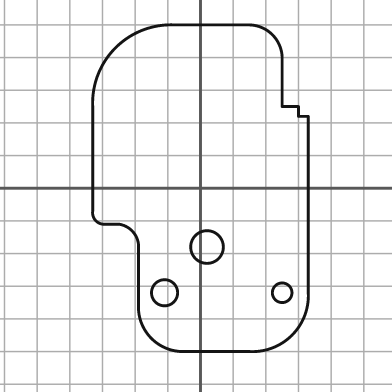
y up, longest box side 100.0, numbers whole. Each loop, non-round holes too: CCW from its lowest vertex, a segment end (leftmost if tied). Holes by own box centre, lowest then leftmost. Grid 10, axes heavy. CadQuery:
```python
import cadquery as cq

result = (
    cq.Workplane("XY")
    .moveTo(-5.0, -50.0)
    .lineTo(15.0, -50.0)
    .threePointArc((28.0, -45.0), (33.0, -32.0))
    .lineTo(33.0, 22.0)
    .lineTo(30.0, 22.0)
    .lineTo(30.0, 25.0)
    .lineTo(25.0, 25.0)
    .lineTo(25.0, 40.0)
    .threePointArc((22.0, 47.0), (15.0, 50.0))
    .lineTo(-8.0, 50.0)
    .threePointArc((-26.0, 43.0), (-33.0, 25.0))
    .lineTo(-33.0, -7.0)
    .threePointArc((-32.0, -10.0), (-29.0, -11.0))
    .lineTo(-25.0, -11.0)
    .threePointArc((-21.0, -13.0), (-19.0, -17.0))
    .lineTo(-19.0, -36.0)
    .threePointArc((-15.0, -46.0), (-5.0, -50.0))
    .close()
    .moveTo(-11.0, -32.0)
    .circle(4.0)
    .moveTo(25.0, -32.0)
    .circle(3.0)
    .moveTo(2.0, -18.0)
    .circle(5.0)
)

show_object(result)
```